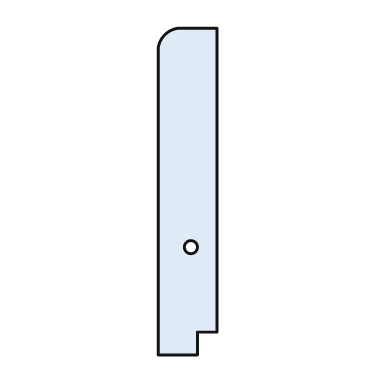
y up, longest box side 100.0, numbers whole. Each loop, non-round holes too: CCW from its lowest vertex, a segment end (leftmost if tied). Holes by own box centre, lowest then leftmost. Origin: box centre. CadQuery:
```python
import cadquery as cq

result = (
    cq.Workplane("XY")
    .moveTo(-9.0, -50.0)
    .lineTo(3.0, -50.0)
    .lineTo(3.0, -43.0)
    .lineTo(9.0, -43.0)
    .lineTo(9.0, 50.0)
    .lineTo(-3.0, 50.0)
    .threePointArc((-7.0, 48.0), (-9.0, 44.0))
    .close()
    .moveTo(1.0, -17.0)
    .circle(2.0)
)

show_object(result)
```